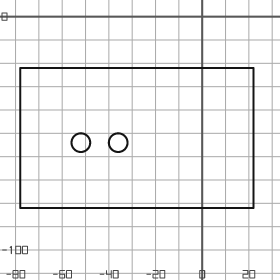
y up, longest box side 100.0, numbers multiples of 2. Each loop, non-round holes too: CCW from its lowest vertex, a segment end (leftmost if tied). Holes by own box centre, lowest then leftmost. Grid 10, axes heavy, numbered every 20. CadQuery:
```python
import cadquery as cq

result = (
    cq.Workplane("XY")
    .moveTo(-78.0, -82.0)
    .lineTo(22.0, -82.0)
    .lineTo(22.0, -22.0)
    .lineTo(-78.0, -22.0)
    .close()
    .moveTo(-52.0, -54.0)
    .circle(4.0)
    .moveTo(-36.0, -54.0)
    .circle(4.0)
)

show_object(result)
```